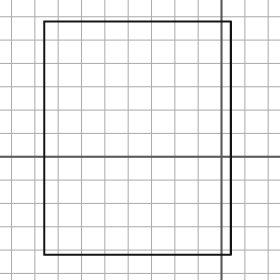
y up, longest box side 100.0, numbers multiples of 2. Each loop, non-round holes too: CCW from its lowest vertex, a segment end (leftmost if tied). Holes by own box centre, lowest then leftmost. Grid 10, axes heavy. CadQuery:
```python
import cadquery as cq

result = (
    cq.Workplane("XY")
    .moveTo(-76.0, -42.0)
    .lineTo(4.0, -42.0)
    .lineTo(4.0, 58.0)
    .lineTo(-76.0, 58.0)
    .close()
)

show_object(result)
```